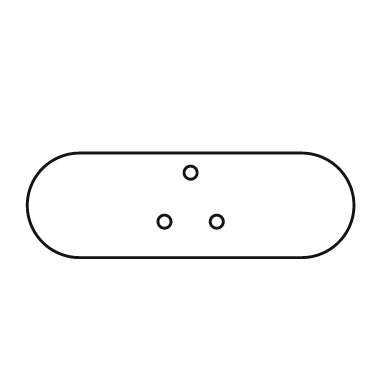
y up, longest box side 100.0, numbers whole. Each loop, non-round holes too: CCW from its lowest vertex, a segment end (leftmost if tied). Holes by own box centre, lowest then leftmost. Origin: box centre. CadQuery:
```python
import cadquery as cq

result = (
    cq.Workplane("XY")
    .moveTo(-34.0, -16.0)
    .lineTo(34.0, -16.0)
    .threePointArc((50.0, 0.0), (34.0, 16.0))
    .lineTo(-34.0, 16.0)
    .threePointArc((-50.0, 0.0), (-34.0, -16.0))
    .close()
    .moveTo(-8.0, -5.0)
    .circle(2.0)
    .moveTo(8.0, -5.0)
    .circle(2.0)
    .moveTo(0.0, 10.0)
    .circle(2.0)
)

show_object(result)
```